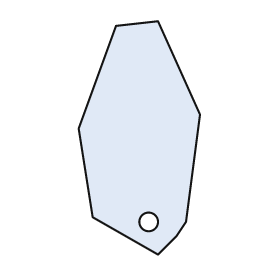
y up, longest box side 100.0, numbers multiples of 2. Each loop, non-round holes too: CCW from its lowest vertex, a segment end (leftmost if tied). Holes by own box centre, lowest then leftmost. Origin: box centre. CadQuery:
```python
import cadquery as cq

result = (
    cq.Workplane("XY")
    .moveTo(8.0, -50.0)
    .lineTo(16.0, -42.0)
    .lineTo(20.0, -36.0)
    .lineTo(26.0, 10.0)
    .lineTo(8.0, 50.0)
    .lineTo(-10.0, 48.0)
    .lineTo(-26.0, 4.0)
    .lineTo(-20.0, -34.0)
    .close()
    .moveTo(4.0, -36.0)
    .circle(4.0)
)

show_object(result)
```